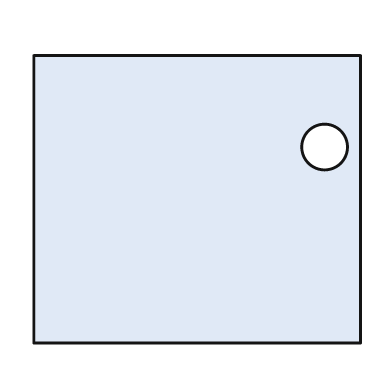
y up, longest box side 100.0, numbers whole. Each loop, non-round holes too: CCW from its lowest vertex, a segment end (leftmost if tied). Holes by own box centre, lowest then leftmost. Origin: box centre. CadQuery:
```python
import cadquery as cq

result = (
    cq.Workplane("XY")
    .moveTo(-50.0, -44.0)
    .lineTo(50.0, -44.0)
    .lineTo(50.0, 44.0)
    .lineTo(-50.0, 44.0)
    .close()
    .moveTo(39.0, 16.0)
    .circle(7.0)
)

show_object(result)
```